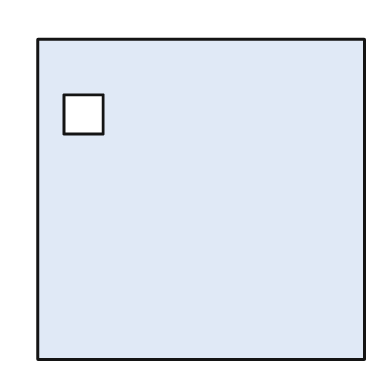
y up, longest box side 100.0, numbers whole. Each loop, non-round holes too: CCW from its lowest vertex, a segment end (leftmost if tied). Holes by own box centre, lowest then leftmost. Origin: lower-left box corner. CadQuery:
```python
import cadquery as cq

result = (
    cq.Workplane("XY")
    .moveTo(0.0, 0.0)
    .lineTo(100.0, 0.0)
    .lineTo(100.0, 98.0)
    .lineTo(0.0, 98.0)
    .close()
    .moveTo(8.0, 69.0)
    .lineTo(20.0, 69.0)
    .lineTo(20.0, 81.0)
    .lineTo(8.0, 81.0)
    .close()
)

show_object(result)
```